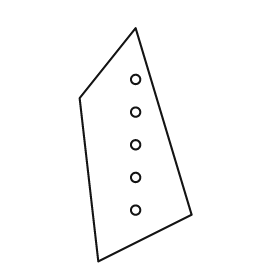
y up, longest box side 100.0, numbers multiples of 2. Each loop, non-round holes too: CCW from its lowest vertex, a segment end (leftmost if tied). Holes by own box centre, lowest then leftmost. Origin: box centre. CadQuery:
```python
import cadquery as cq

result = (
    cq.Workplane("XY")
    .moveTo(-16.0, -50.0)
    .lineTo(24.0, -30.0)
    .lineTo(0.0, 50.0)
    .lineTo(-24.0, 20.0)
    .close()
    .moveTo(0.0, -28.0)
    .circle(2.0)
    .moveTo(0.0, -14.0)
    .circle(2.0)
    .moveTo(0.0, 0.0)
    .circle(2.0)
    .moveTo(0.0, 14.0)
    .circle(2.0)
    .moveTo(0.0, 28.0)
    .circle(2.0)
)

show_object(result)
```